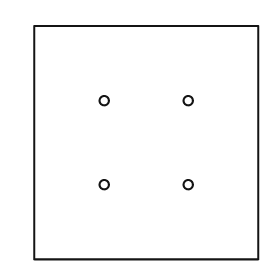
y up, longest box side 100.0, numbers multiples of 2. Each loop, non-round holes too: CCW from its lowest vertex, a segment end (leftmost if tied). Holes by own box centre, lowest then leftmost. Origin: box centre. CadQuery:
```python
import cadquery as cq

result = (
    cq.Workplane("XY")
    .moveTo(-48.0, -50.0)
    .lineTo(48.0, -50.0)
    .lineTo(48.0, 50.0)
    .lineTo(-48.0, 50.0)
    .close()
    .moveTo(-18.0, -18.0)
    .circle(2.0)
    .moveTo(18.0, -18.0)
    .circle(2.0)
    .moveTo(-18.0, 18.0)
    .circle(2.0)
    .moveTo(18.0, 18.0)
    .circle(2.0)
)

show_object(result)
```